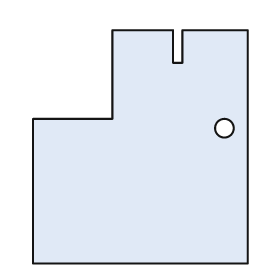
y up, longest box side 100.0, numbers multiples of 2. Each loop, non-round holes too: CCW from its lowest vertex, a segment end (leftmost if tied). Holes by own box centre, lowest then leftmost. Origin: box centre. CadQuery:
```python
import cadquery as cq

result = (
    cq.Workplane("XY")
    .moveTo(-46.0, -50.0)
    .lineTo(46.0, -50.0)
    .lineTo(46.0, 50.0)
    .lineTo(18.0, 50.0)
    .lineTo(18.0, 36.0)
    .lineTo(14.0, 36.0)
    .lineTo(14.0, 50.0)
    .lineTo(-12.0, 50.0)
    .lineTo(-12.0, 12.0)
    .lineTo(-46.0, 12.0)
    .close()
    .moveTo(36.0, 8.0)
    .circle(4.0)
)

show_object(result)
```